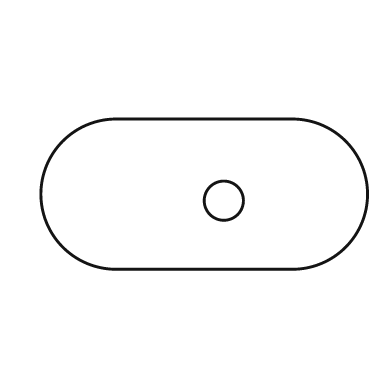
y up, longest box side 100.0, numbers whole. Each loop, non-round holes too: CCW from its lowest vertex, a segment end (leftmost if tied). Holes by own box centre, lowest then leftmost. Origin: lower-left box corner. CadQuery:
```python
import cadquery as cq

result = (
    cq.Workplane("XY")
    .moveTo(23.0, 0.0)
    .lineTo(77.0, 0.0)
    .threePointArc((100.0, 23.0), (77.0, 46.0))
    .lineTo(23.0, 46.0)
    .threePointArc((0.0, 23.0), (23.0, 0.0))
    .close()
    .moveTo(56.0, 21.0)
    .circle(6.0)
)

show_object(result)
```